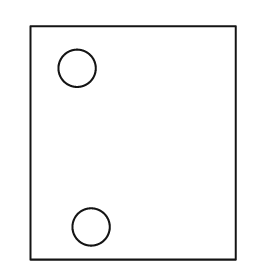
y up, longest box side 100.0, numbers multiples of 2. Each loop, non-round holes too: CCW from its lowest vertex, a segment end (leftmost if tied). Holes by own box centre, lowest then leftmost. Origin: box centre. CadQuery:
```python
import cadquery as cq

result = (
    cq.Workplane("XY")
    .moveTo(-44.0, -50.0)
    .lineTo(44.0, -50.0)
    .lineTo(44.0, 50.0)
    .lineTo(-44.0, 50.0)
    .close()
    .moveTo(-18.0, -36.0)
    .circle(8.0)
    .moveTo(-24.0, 32.0)
    .circle(8.0)
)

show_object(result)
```